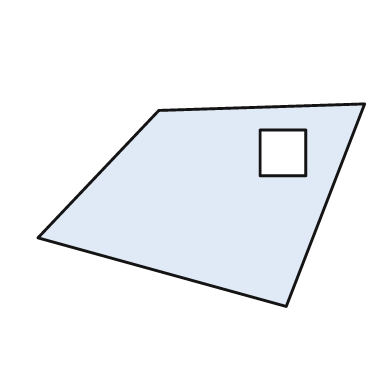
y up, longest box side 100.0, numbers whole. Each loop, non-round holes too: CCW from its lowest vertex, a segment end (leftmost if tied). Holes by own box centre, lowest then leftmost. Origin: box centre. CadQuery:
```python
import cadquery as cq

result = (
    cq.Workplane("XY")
    .moveTo(26.0, -31.0)
    .lineTo(50.0, 31.0)
    .lineTo(-13.0, 29.0)
    .lineTo(-50.0, -10.0)
    .close()
    .moveTo(18.0, 9.0)
    .lineTo(32.0, 9.0)
    .lineTo(32.0, 23.0)
    .lineTo(18.0, 23.0)
    .close()
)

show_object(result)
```